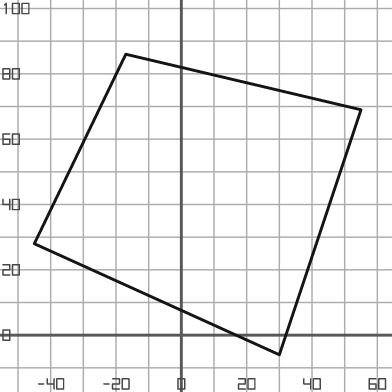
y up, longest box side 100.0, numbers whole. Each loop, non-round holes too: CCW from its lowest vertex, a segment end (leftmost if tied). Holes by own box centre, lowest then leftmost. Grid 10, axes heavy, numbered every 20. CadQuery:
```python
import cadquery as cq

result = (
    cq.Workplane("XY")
    .moveTo(30.0, -6.0)
    .lineTo(55.0, 69.0)
    .lineTo(-17.0, 86.0)
    .lineTo(-45.0, 28.0)
    .close()
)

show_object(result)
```